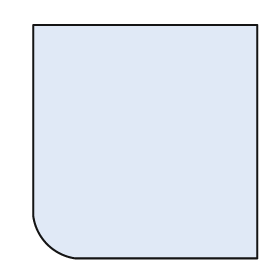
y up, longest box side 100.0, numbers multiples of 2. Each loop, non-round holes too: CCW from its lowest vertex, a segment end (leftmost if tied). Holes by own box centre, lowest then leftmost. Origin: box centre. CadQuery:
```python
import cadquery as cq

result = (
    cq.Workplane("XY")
    .moveTo(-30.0, -50.0)
    .lineTo(48.0, -50.0)
    .lineTo(48.0, 50.0)
    .lineTo(-48.0, 50.0)
    .lineTo(-48.0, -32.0)
    .threePointArc((-42.0, -44.0), (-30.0, -50.0))
    .close()
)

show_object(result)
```